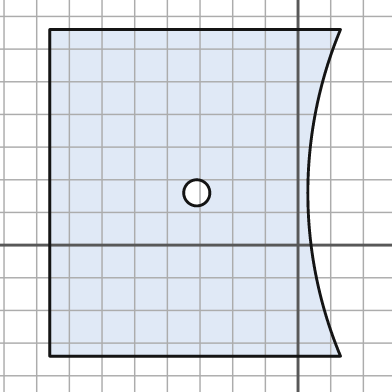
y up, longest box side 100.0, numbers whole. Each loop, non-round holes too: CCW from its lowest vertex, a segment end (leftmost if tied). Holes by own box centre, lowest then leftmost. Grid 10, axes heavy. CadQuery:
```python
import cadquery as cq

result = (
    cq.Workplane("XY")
    .moveTo(-76.0, -34.0)
    .lineTo(13.0, -34.0)
    .threePointArc((3.0, 16.0), (13.0, 66.0))
    .lineTo(-76.0, 66.0)
    .close()
    .moveTo(-31.0, 16.0)
    .circle(4.0)
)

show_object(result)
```